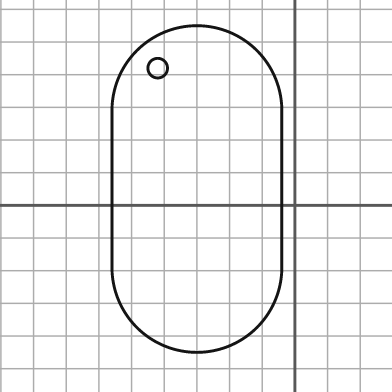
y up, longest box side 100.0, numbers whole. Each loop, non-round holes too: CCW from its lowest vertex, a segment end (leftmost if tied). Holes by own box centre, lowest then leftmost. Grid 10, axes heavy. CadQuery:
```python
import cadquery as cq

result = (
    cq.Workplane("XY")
    .moveTo(-56.0, -19.0)
    .threePointArc((-30.0, -45.0), (-4.0, -19.0))
    .lineTo(-4.0, 29.0)
    .threePointArc((-30.0, 55.0), (-56.0, 29.0))
    .close()
    .moveTo(-42.0, 42.0)
    .circle(3.0)
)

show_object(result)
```